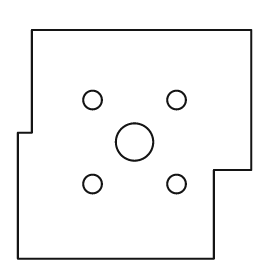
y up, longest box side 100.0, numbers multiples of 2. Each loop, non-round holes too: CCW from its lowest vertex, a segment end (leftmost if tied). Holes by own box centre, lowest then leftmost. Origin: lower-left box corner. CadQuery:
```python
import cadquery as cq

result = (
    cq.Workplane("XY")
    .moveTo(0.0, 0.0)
    .lineTo(84.0, 0.0)
    .lineTo(84.0, 38.0)
    .lineTo(100.0, 38.0)
    .lineTo(100.0, 98.0)
    .lineTo(6.0, 98.0)
    .lineTo(6.0, 54.0)
    .lineTo(0.0, 54.0)
    .close()
    .moveTo(32.0, 32.0)
    .circle(4.0)
    .moveTo(68.0, 32.0)
    .circle(4.0)
    .moveTo(50.0, 50.0)
    .circle(8.0)
    .moveTo(32.0, 68.0)
    .circle(4.0)
    .moveTo(68.0, 68.0)
    .circle(4.0)
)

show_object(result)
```